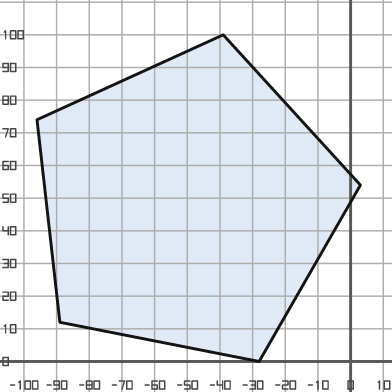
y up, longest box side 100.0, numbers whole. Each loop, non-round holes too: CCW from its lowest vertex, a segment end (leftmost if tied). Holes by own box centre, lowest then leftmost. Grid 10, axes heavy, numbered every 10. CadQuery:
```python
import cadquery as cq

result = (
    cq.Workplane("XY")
    .moveTo(-28.0, 0.0)
    .lineTo(3.0, 54.0)
    .lineTo(-39.0, 100.0)
    .lineTo(-96.0, 74.0)
    .lineTo(-89.0, 12.0)
    .close()
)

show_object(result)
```